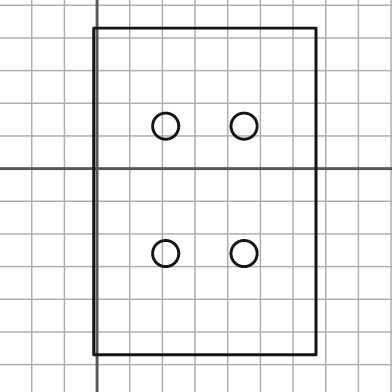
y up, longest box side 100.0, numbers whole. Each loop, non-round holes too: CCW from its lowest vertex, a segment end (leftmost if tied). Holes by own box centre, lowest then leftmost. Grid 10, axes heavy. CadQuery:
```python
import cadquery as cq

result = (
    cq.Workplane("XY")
    .moveTo(-1.0, -57.0)
    .lineTo(67.0, -57.0)
    .lineTo(67.0, 43.0)
    .lineTo(-1.0, 43.0)
    .close()
    .moveTo(21.0, -26.0)
    .circle(4.0)
    .moveTo(45.0, -26.0)
    .circle(4.0)
    .moveTo(21.0, 13.0)
    .circle(4.0)
    .moveTo(45.0, 13.0)
    .circle(4.0)
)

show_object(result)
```